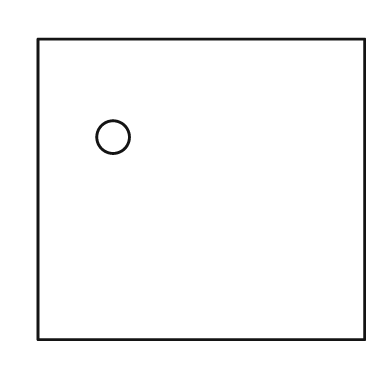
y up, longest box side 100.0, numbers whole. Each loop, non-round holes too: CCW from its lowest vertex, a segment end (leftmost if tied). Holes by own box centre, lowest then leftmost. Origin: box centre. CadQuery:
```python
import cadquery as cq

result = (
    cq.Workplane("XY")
    .moveTo(-50.0, -46.0)
    .lineTo(50.0, -46.0)
    .lineTo(50.0, 46.0)
    .lineTo(-50.0, 46.0)
    .close()
    .moveTo(-27.0, 16.0)
    .circle(5.0)
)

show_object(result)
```